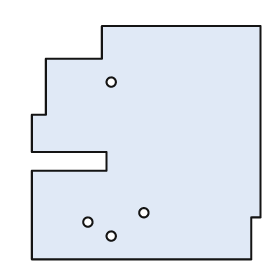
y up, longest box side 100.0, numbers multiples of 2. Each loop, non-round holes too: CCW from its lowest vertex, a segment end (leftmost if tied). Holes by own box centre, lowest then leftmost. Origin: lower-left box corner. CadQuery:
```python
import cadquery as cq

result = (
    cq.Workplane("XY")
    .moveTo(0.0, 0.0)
    .lineTo(94.0, 0.0)
    .lineTo(94.0, 18.0)
    .lineTo(98.0, 18.0)
    .lineTo(98.0, 100.0)
    .lineTo(30.0, 100.0)
    .lineTo(30.0, 86.0)
    .lineTo(6.0, 86.0)
    .lineTo(6.0, 62.0)
    .lineTo(0.0, 62.0)
    .lineTo(0.0, 46.0)
    .lineTo(32.0, 46.0)
    .lineTo(32.0, 38.0)
    .lineTo(0.0, 38.0)
    .close()
    .moveTo(34.0, 10.0)
    .circle(2.0)
    .moveTo(24.0, 16.0)
    .circle(2.0)
    .moveTo(48.0, 20.0)
    .circle(2.0)
    .moveTo(34.0, 76.0)
    .circle(2.0)
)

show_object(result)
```